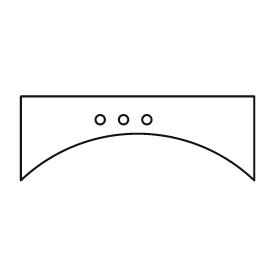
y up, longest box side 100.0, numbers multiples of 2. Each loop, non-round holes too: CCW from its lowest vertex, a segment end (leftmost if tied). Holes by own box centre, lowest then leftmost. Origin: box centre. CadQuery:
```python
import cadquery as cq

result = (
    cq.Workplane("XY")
    .moveTo(-50.0, -18.0)
    .threePointArc((0.0, 2.0), (50.0, -18.0))
    .lineTo(50.0, 18.0)
    .lineTo(-50.0, 18.0)
    .close()
    .moveTo(-16.0, 8.0)
    .circle(2.0)
    .moveTo(-6.0, 8.0)
    .circle(2.0)
    .moveTo(4.0, 8.0)
    .circle(2.0)
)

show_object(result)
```